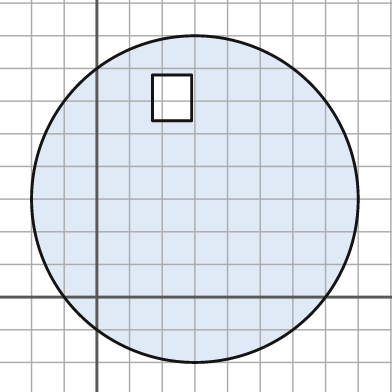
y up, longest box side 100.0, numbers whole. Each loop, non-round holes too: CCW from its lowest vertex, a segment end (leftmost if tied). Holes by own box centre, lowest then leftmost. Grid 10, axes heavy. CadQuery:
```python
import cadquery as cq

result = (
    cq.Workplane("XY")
    .moveTo(30.0, 30.0)
    .circle(50.0)
    .moveTo(17.0, 54.0)
    .lineTo(29.0, 54.0)
    .lineTo(29.0, 68.0)
    .lineTo(17.0, 68.0)
    .close()
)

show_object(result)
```